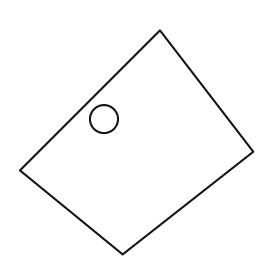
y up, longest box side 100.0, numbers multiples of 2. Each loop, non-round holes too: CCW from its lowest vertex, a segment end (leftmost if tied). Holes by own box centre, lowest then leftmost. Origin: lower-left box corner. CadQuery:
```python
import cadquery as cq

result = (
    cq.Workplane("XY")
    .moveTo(44.0, 0.0)
    .lineTo(100.0, 44.0)
    .lineTo(60.0, 96.0)
    .lineTo(0.0, 36.0)
    .close()
    .moveTo(36.0, 58.0)
    .circle(6.0)
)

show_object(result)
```